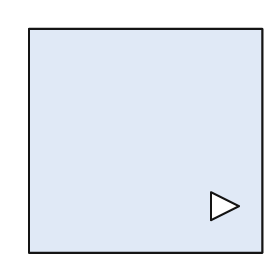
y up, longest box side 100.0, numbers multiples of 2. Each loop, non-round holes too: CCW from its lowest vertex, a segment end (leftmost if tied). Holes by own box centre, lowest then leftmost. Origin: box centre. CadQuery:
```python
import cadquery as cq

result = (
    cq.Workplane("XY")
    .moveTo(-50.0, -48.0)
    .lineTo(50.0, -48.0)
    .lineTo(50.0, 48.0)
    .lineTo(-50.0, 48.0)
    .close()
    .moveTo(28.0, -34.0)
    .lineTo(40.0, -28.0)
    .lineTo(28.0, -22.0)
    .close()
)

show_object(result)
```